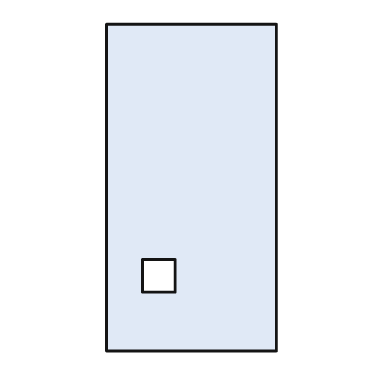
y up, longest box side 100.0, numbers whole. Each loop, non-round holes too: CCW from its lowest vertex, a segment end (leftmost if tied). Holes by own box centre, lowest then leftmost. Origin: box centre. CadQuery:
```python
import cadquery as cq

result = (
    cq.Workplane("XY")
    .moveTo(-26.0, -50.0)
    .lineTo(26.0, -50.0)
    .lineTo(26.0, 50.0)
    .lineTo(-26.0, 50.0)
    .close()
    .moveTo(-15.0, -32.0)
    .lineTo(-5.0, -32.0)
    .lineTo(-5.0, -22.0)
    .lineTo(-15.0, -22.0)
    .close()
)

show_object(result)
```